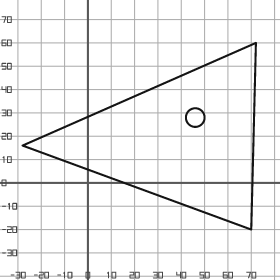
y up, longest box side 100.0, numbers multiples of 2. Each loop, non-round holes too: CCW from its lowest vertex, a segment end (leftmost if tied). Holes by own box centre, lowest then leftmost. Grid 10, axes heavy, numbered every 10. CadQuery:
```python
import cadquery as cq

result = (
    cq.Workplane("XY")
    .moveTo(70.0, -20.0)
    .lineTo(72.0, 60.0)
    .lineTo(-28.0, 16.0)
    .close()
    .moveTo(46.0, 28.0)
    .circle(4.0)
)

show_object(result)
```